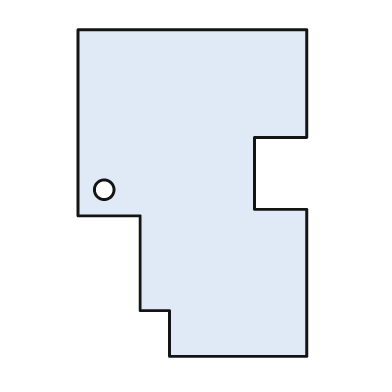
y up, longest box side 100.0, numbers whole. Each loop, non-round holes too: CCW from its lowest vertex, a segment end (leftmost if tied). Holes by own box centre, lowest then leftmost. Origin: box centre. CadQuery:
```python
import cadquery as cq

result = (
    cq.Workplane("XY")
    .moveTo(-7.0, -50.0)
    .lineTo(35.0, -50.0)
    .lineTo(35.0, -5.0)
    .lineTo(19.0, -5.0)
    .lineTo(19.0, 17.0)
    .lineTo(35.0, 17.0)
    .lineTo(35.0, 50.0)
    .lineTo(-35.0, 50.0)
    .lineTo(-35.0, -7.0)
    .lineTo(-16.0, -7.0)
    .lineTo(-16.0, -36.0)
    .lineTo(-7.0, -36.0)
    .close()
    .moveTo(-27.0, 1.0)
    .circle(3.0)
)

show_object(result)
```